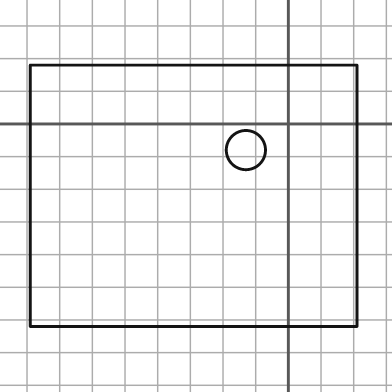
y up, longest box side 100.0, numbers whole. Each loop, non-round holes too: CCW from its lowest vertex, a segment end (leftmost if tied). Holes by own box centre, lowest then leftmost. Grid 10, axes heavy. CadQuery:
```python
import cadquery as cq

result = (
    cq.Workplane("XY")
    .moveTo(-79.0, -62.0)
    .lineTo(21.0, -62.0)
    .lineTo(21.0, 18.0)
    .lineTo(-79.0, 18.0)
    .close()
    .moveTo(-13.0, -8.0)
    .circle(6.0)
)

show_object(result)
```